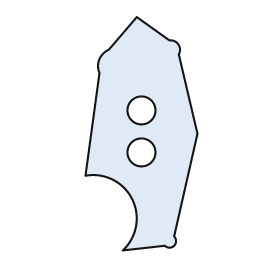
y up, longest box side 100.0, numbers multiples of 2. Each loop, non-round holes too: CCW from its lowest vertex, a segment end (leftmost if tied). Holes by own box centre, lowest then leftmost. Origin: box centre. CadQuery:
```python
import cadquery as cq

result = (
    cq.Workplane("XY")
    .moveTo(-8.0, -50.0)
    .lineTo(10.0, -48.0)
    .threePointArc((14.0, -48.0), (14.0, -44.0))
    .lineTo(24.0, 0.0)
    .lineTo(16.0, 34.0)
    .threePointArc((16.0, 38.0), (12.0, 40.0))
    .lineTo(-2.0, 50.0)
    .lineTo(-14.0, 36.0)
    .threePointArc((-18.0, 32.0), (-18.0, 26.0))
    .lineTo(-24.0, -18.0)
    .threePointArc((-4.0, -28.0), (-8.0, -50.0))
    .close()
    .moveTo(0.0, -8.0)
    .circle(6.0)
    .moveTo(0.0, 10.0)
    .circle(6.0)
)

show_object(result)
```